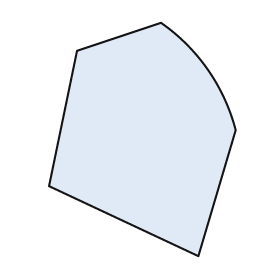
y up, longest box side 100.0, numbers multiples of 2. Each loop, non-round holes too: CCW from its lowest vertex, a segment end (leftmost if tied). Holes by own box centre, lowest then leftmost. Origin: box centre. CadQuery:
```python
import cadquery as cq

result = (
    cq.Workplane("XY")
    .moveTo(24.0, -50.0)
    .lineTo(40.0, 4.0)
    .threePointArc((28.0, 30.0), (8.0, 50.0))
    .lineTo(-28.0, 38.0)
    .lineTo(-40.0, -20.0)
    .close()
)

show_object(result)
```